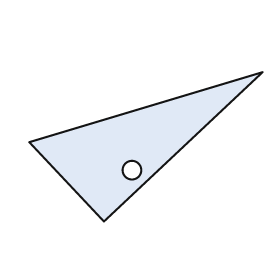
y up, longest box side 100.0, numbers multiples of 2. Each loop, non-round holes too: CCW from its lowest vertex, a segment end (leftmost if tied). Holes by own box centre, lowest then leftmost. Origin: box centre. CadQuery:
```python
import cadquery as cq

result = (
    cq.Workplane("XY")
    .moveTo(-18.0, -32.0)
    .lineTo(50.0, 32.0)
    .lineTo(-50.0, 2.0)
    .close()
    .moveTo(-6.0, -10.0)
    .circle(4.0)
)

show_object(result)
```